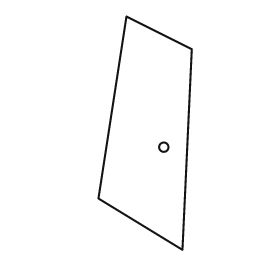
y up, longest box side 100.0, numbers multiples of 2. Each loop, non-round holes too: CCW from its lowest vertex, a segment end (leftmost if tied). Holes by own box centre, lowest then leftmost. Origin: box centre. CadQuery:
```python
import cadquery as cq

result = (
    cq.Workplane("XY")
    .moveTo(16.0, -50.0)
    .lineTo(20.0, 36.0)
    .lineTo(-8.0, 50.0)
    .lineTo(-20.0, -28.0)
    .close()
    .moveTo(8.0, -6.0)
    .circle(2.0)
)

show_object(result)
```